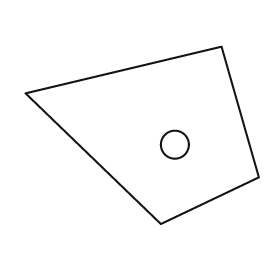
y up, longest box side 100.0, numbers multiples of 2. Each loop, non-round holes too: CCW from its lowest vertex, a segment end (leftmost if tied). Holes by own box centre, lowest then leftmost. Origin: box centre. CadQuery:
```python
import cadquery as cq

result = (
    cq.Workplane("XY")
    .moveTo(8.0, -38.0)
    .lineTo(50.0, -18.0)
    .lineTo(34.0, 38.0)
    .lineTo(-50.0, 18.0)
    .close()
    .moveTo(14.0, -4.0)
    .circle(6.0)
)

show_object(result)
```